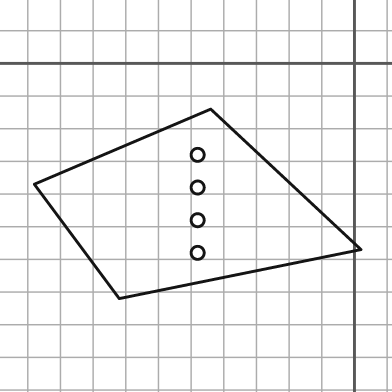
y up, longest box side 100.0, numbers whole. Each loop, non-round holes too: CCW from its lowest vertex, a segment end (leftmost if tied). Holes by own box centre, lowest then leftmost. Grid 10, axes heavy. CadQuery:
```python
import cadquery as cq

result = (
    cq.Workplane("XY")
    .moveTo(-72.0, -72.0)
    .lineTo(2.0, -57.0)
    .lineTo(-44.0, -14.0)
    .lineTo(-98.0, -37.0)
    .close()
    .moveTo(-48.0, -58.0)
    .circle(2.0)
    .moveTo(-48.0, -48.0)
    .circle(2.0)
    .moveTo(-48.0, -38.0)
    .circle(2.0)
    .moveTo(-48.0, -28.0)
    .circle(2.0)
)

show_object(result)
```